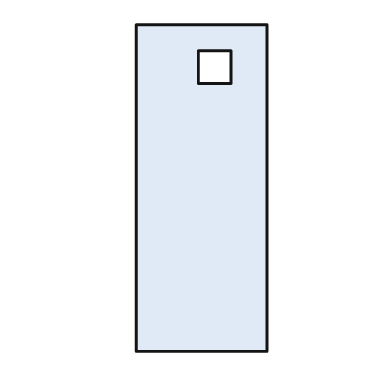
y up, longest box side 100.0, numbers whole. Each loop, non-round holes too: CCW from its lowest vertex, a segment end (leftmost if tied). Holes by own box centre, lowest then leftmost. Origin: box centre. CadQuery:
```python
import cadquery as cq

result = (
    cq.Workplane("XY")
    .moveTo(-20.0, -50.0)
    .lineTo(20.0, -50.0)
    .lineTo(20.0, 50.0)
    .lineTo(-20.0, 50.0)
    .close()
    .moveTo(-1.0, 32.0)
    .lineTo(9.0, 32.0)
    .lineTo(9.0, 42.0)
    .lineTo(-1.0, 42.0)
    .close()
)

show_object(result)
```